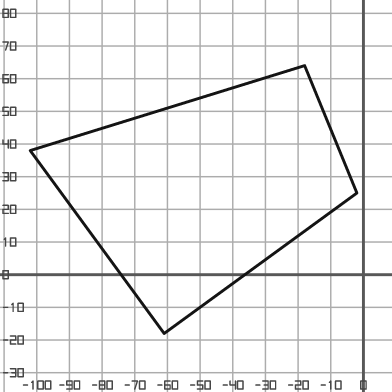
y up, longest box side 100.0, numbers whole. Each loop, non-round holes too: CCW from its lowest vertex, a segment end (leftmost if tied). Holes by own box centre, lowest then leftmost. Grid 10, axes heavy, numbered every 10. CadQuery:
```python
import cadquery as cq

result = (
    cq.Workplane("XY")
    .moveTo(-61.0, -18.0)
    .lineTo(-2.0, 25.0)
    .lineTo(-18.0, 64.0)
    .lineTo(-102.0, 38.0)
    .close()
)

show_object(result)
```